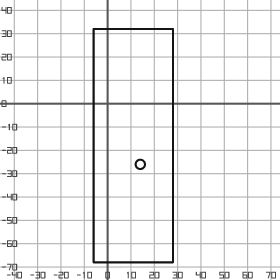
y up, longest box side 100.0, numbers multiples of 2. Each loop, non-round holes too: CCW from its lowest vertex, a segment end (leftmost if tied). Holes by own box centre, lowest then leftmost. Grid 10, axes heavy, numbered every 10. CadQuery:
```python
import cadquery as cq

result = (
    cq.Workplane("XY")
    .moveTo(-6.0, -68.0)
    .lineTo(28.0, -68.0)
    .lineTo(28.0, 32.0)
    .lineTo(-6.0, 32.0)
    .close()
    .moveTo(14.0, -26.0)
    .circle(2.0)
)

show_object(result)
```